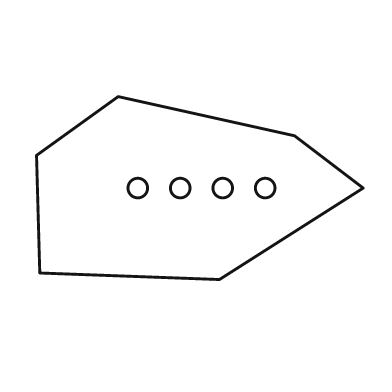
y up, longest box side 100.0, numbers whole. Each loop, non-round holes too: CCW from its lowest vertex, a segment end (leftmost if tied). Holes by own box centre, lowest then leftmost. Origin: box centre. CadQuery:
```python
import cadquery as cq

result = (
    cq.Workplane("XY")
    .moveTo(6.0, -28.0)
    .lineTo(50.0, 0.0)
    .lineTo(29.0, 16.0)
    .lineTo(-25.0, 28.0)
    .lineTo(-50.0, 10.0)
    .lineTo(-49.0, -26.0)
    .close()
    .moveTo(-19.0, 0.0)
    .circle(3.0)
    .moveTo(-6.0, 0.0)
    .circle(3.0)
    .moveTo(7.0, 0.0)
    .circle(3.0)
    .moveTo(20.0, 0.0)
    .circle(3.0)
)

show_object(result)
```